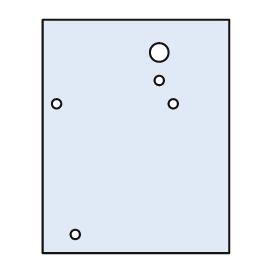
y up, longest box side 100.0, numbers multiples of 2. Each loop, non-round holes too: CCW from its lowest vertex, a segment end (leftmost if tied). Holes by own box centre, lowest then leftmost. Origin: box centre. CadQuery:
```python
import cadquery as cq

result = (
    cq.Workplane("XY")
    .moveTo(-40.0, -50.0)
    .lineTo(40.0, -50.0)
    .lineTo(40.0, 50.0)
    .lineTo(-40.0, 50.0)
    .close()
    .moveTo(-26.0, -42.0)
    .circle(2.0)
    .moveTo(-34.0, 14.0)
    .circle(2.0)
    .moveTo(16.0, 14.0)
    .circle(2.0)
    .moveTo(10.0, 24.0)
    .circle(2.0)
    .moveTo(10.0, 36.0)
    .circle(4.0)
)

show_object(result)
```